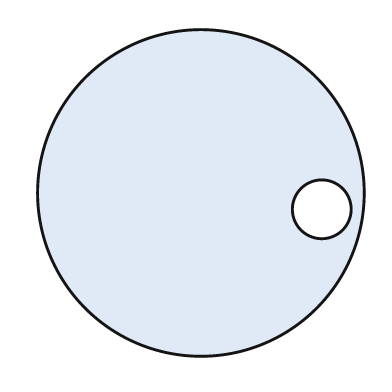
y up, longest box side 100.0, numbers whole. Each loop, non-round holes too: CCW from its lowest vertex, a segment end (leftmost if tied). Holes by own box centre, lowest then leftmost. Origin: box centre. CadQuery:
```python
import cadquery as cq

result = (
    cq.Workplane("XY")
    .moveTo(0.0, 0.0)
    .circle(50.0)
    .moveTo(37.0, -5.0)
    .circle(9.0)
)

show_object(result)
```